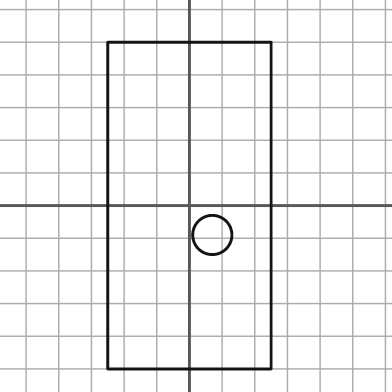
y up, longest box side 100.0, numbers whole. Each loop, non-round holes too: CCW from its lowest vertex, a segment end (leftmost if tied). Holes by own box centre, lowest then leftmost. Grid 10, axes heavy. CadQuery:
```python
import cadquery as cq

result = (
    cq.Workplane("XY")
    .moveTo(-25.0, -50.0)
    .lineTo(25.0, -50.0)
    .lineTo(25.0, 50.0)
    .lineTo(-25.0, 50.0)
    .close()
    .moveTo(7.0, -9.0)
    .circle(6.0)
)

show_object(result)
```